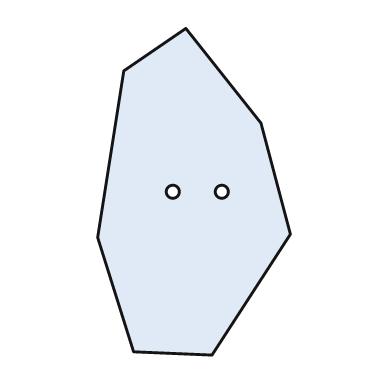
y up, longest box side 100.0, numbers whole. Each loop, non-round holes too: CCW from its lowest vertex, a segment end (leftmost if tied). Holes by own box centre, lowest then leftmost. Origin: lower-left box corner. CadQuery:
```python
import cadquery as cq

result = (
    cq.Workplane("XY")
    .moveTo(35.0, 0.0)
    .lineTo(59.0, 37.0)
    .lineTo(50.0, 71.0)
    .lineTo(27.0, 100.0)
    .lineTo(8.0, 87.0)
    .lineTo(0.0, 36.0)
    .lineTo(11.0, 1.0)
    .close()
    .moveTo(23.0, 50.0)
    .circle(2.0)
    .moveTo(38.0, 50.0)
    .circle(2.0)
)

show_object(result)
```